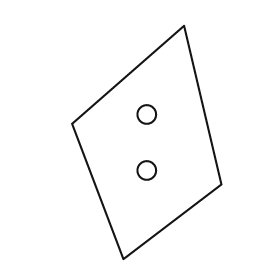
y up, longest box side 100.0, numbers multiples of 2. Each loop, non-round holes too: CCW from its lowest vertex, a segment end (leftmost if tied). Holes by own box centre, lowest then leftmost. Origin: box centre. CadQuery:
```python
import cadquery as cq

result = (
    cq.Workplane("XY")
    .moveTo(-10.0, -50.0)
    .lineTo(32.0, -18.0)
    .lineTo(16.0, 50.0)
    .lineTo(-32.0, 8.0)
    .close()
    .moveTo(0.0, -12.0)
    .circle(4.0)
    .moveTo(0.0, 12.0)
    .circle(4.0)
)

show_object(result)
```